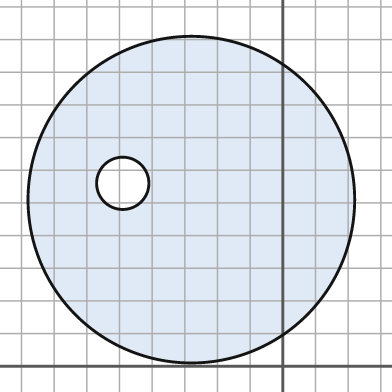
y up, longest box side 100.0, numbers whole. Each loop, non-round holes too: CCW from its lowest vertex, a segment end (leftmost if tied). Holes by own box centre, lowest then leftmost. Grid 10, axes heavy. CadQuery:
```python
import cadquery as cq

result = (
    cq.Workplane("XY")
    .moveTo(-28.0, 51.0)
    .circle(50.0)
    .moveTo(-49.0, 56.0)
    .circle(8.0)
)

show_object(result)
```